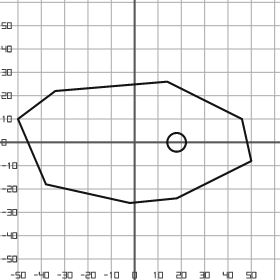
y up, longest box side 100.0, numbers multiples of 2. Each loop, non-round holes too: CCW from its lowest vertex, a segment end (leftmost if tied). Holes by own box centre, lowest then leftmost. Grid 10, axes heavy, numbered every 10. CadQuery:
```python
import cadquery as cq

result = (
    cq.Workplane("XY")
    .moveTo(-2.0, -26.0)
    .lineTo(18.0, -24.0)
    .lineTo(50.0, -8.0)
    .lineTo(46.0, 10.0)
    .lineTo(14.0, 26.0)
    .lineTo(-34.0, 22.0)
    .lineTo(-50.0, 10.0)
    .lineTo(-38.0, -18.0)
    .close()
    .moveTo(18.0, 0.0)
    .circle(4.0)
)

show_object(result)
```